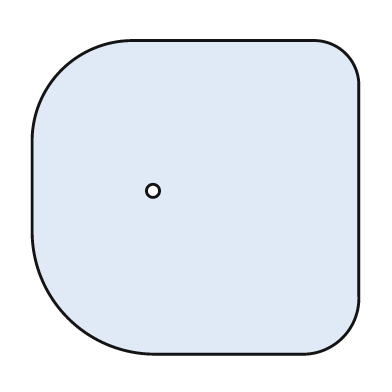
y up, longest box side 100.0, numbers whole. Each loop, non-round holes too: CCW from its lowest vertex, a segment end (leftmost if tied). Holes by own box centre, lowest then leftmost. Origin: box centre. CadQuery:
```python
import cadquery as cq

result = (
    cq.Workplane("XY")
    .moveTo(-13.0, -48.0)
    .lineTo(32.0, -48.0)
    .threePointArc((45.0, -43.0), (50.0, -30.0))
    .lineTo(50.0, 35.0)
    .threePointArc((46.0, 44.0), (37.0, 48.0))
    .lineTo(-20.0, 48.0)
    .threePointArc((-41.0, 39.0), (-50.0, 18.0))
    .lineTo(-50.0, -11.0)
    .threePointArc((-39.0, -37.0), (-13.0, -48.0))
    .close()
    .moveTo(-13.0, 2.0)
    .circle(2.0)
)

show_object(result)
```